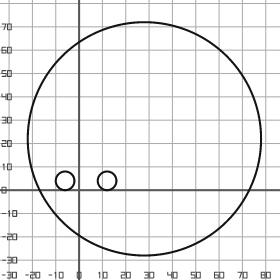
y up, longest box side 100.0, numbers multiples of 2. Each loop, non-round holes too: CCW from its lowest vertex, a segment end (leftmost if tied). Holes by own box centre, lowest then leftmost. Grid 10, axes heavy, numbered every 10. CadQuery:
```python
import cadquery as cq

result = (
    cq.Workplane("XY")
    .moveTo(28.0, 22.0)
    .circle(50.0)
    .moveTo(-6.0, 4.0)
    .circle(4.0)
    .moveTo(12.0, 4.0)
    .circle(4.0)
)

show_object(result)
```